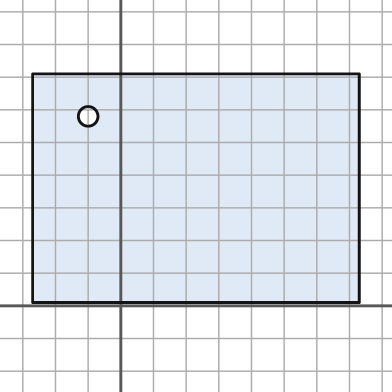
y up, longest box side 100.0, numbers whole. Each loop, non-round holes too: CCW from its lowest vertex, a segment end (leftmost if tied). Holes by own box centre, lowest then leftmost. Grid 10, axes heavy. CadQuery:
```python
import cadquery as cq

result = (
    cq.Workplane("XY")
    .moveTo(-27.0, 1.0)
    .lineTo(73.0, 1.0)
    .lineTo(73.0, 71.0)
    .lineTo(-27.0, 71.0)
    .close()
    .moveTo(-10.0, 58.0)
    .circle(3.0)
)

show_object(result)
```